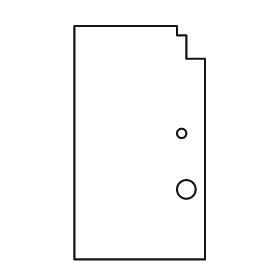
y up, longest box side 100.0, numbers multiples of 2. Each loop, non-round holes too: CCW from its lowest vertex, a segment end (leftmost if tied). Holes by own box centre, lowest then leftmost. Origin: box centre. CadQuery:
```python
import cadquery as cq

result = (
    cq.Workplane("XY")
    .moveTo(-28.0, -50.0)
    .lineTo(28.0, -50.0)
    .lineTo(28.0, 36.0)
    .lineTo(20.0, 36.0)
    .lineTo(20.0, 46.0)
    .lineTo(16.0, 46.0)
    .lineTo(16.0, 50.0)
    .lineTo(-28.0, 50.0)
    .close()
    .moveTo(20.0, -20.0)
    .circle(4.0)
    .moveTo(18.0, 4.0)
    .circle(2.0)
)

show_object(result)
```